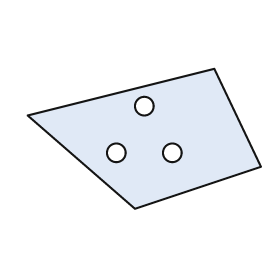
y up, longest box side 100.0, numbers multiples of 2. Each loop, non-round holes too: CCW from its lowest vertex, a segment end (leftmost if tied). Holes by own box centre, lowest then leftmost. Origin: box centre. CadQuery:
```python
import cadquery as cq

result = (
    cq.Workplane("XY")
    .moveTo(-4.0, -30.0)
    .lineTo(50.0, -12.0)
    .lineTo(30.0, 30.0)
    .lineTo(-50.0, 10.0)
    .close()
    .moveTo(-12.0, -6.0)
    .circle(4.0)
    .moveTo(12.0, -6.0)
    .circle(4.0)
    .moveTo(0.0, 14.0)
    .circle(4.0)
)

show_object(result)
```